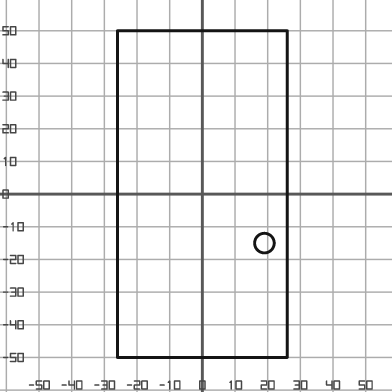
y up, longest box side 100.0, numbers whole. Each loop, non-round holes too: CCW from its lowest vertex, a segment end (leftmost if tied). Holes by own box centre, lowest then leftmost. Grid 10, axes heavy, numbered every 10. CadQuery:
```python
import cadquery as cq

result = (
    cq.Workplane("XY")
    .moveTo(-26.0, -50.0)
    .lineTo(26.0, -50.0)
    .lineTo(26.0, 50.0)
    .lineTo(-26.0, 50.0)
    .close()
    .moveTo(19.0, -15.0)
    .circle(3.0)
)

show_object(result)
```